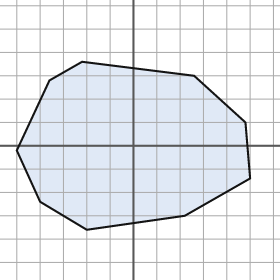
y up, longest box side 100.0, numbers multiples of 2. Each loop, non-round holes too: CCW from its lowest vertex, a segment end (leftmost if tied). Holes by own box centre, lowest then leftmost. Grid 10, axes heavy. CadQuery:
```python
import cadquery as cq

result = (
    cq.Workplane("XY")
    .moveTo(-20.0, -36.0)
    .lineTo(22.0, -30.0)
    .lineTo(50.0, -14.0)
    .lineTo(48.0, 10.0)
    .lineTo(26.0, 30.0)
    .lineTo(-22.0, 36.0)
    .lineTo(-36.0, 28.0)
    .lineTo(-50.0, -2.0)
    .lineTo(-40.0, -24.0)
    .close()
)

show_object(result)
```